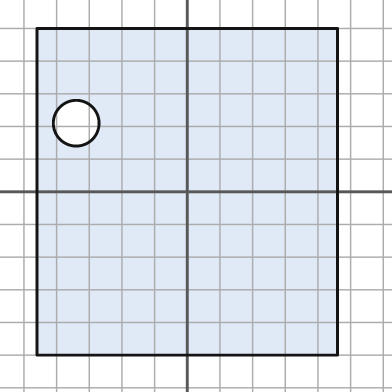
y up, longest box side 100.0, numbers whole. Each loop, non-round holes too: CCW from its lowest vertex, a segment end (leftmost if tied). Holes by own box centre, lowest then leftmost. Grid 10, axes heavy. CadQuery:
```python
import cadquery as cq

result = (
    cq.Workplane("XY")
    .moveTo(-46.0, -50.0)
    .lineTo(46.0, -50.0)
    .lineTo(46.0, 50.0)
    .lineTo(-46.0, 50.0)
    .close()
    .moveTo(-34.0, 21.0)
    .circle(7.0)
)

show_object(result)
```